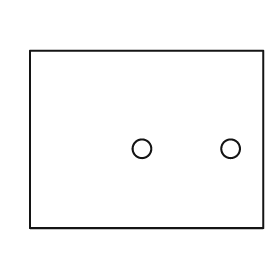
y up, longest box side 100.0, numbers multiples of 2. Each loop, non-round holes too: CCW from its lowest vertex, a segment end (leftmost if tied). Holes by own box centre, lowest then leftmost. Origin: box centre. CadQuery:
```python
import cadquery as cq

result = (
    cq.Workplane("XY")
    .moveTo(-50.0, -38.0)
    .lineTo(50.0, -38.0)
    .lineTo(50.0, 38.0)
    .lineTo(-50.0, 38.0)
    .close()
    .moveTo(-2.0, -4.0)
    .circle(4.0)
    .moveTo(36.0, -4.0)
    .circle(4.0)
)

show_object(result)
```